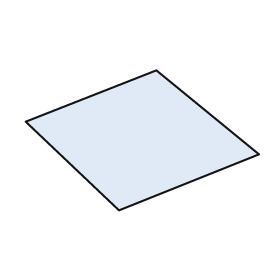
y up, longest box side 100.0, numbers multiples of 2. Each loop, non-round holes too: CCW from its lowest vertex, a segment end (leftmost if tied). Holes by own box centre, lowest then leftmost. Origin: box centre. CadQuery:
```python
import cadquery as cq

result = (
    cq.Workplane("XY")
    .moveTo(-10.0, -30.0)
    .lineTo(50.0, -6.0)
    .lineTo(6.0, 30.0)
    .lineTo(-50.0, 8.0)
    .close()
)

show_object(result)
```